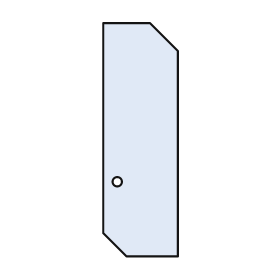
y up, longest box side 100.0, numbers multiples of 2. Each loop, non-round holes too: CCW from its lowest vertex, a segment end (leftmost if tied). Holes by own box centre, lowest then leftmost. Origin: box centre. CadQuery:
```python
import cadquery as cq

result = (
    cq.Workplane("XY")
    .moveTo(-6.0, -50.0)
    .lineTo(16.0, -50.0)
    .lineTo(16.0, 38.0)
    .lineTo(4.0, 50.0)
    .lineTo(-16.0, 50.0)
    .lineTo(-16.0, -40.0)
    .close()
    .moveTo(-10.0, -18.0)
    .circle(2.0)
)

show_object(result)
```